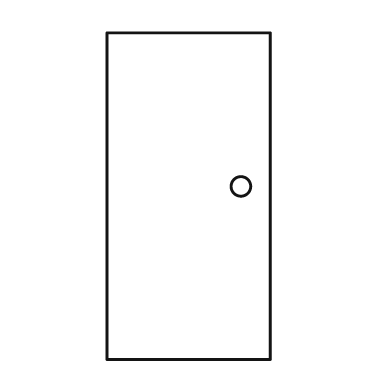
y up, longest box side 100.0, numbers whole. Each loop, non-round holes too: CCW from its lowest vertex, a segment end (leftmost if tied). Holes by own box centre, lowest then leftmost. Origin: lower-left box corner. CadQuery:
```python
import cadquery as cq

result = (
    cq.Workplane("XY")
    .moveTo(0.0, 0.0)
    .lineTo(50.0, 0.0)
    .lineTo(50.0, 100.0)
    .lineTo(0.0, 100.0)
    .close()
    .moveTo(41.0, 53.0)
    .circle(3.0)
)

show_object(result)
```